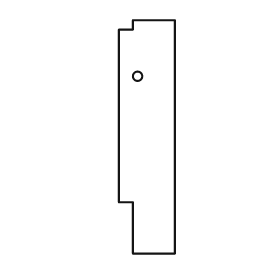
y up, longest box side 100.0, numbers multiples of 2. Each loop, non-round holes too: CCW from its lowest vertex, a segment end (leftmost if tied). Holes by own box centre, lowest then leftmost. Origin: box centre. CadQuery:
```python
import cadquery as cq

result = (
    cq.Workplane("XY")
    .moveTo(-6.0, -50.0)
    .lineTo(12.0, -50.0)
    .lineTo(12.0, 50.0)
    .lineTo(-6.0, 50.0)
    .lineTo(-6.0, 46.0)
    .lineTo(-12.0, 46.0)
    .lineTo(-12.0, -28.0)
    .lineTo(-6.0, -28.0)
    .close()
    .moveTo(-4.0, 26.0)
    .circle(2.0)
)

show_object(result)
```